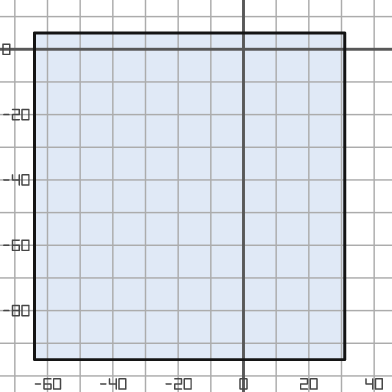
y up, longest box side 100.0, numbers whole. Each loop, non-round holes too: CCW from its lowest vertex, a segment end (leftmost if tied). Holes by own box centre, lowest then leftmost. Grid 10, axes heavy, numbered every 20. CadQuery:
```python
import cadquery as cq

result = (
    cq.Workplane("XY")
    .moveTo(-64.0, -95.0)
    .lineTo(31.0, -95.0)
    .lineTo(31.0, 5.0)
    .lineTo(-64.0, 5.0)
    .close()
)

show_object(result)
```